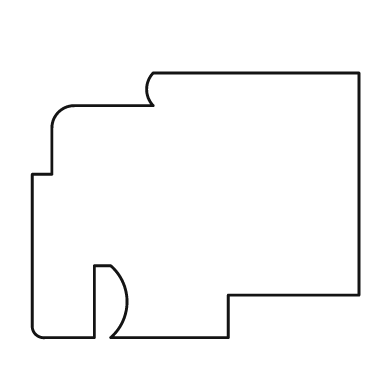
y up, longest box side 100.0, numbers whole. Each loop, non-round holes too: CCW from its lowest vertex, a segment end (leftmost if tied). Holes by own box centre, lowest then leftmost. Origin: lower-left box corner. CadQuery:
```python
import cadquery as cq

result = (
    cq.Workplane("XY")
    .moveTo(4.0, 0.0)
    .lineTo(19.0, 0.0)
    .lineTo(19.0, 22.0)
    .lineTo(24.0, 22.0)
    .threePointArc((29.0, 11.0), (24.0, 0.0))
    .lineTo(60.0, 0.0)
    .lineTo(60.0, 13.0)
    .lineTo(100.0, 13.0)
    .lineTo(100.0, 81.0)
    .lineTo(37.0, 81.0)
    .threePointArc((35.0, 76.0), (37.0, 71.0))
    .lineTo(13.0, 71.0)
    .threePointArc((8.0, 69.0), (6.0, 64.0))
    .lineTo(6.0, 50.0)
    .lineTo(0.0, 50.0)
    .lineTo(0.0, 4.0)
    .threePointArc((1.0, 1.0), (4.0, 0.0))
    .close()
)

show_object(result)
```